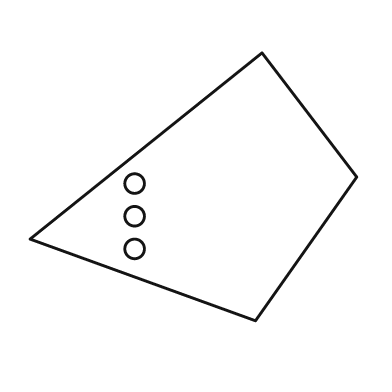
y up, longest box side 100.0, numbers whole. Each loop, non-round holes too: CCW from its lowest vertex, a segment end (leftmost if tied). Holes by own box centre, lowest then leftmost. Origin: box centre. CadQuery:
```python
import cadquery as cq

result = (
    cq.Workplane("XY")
    .moveTo(19.0, -41.0)
    .lineTo(50.0, 3.0)
    .lineTo(21.0, 41.0)
    .lineTo(-50.0, -16.0)
    .close()
    .moveTo(-18.0, -19.0)
    .circle(3.0)
    .moveTo(-18.0, -9.0)
    .circle(3.0)
    .moveTo(-18.0, 1.0)
    .circle(3.0)
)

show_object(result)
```